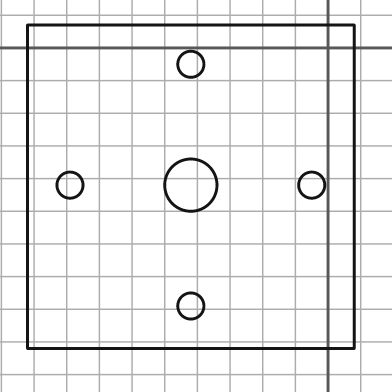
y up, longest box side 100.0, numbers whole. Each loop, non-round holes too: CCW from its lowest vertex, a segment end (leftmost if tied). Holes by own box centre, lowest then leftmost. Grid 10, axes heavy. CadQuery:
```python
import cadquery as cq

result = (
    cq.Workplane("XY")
    .moveTo(-92.0, -92.0)
    .lineTo(8.0, -92.0)
    .lineTo(8.0, 7.0)
    .lineTo(-92.0, 7.0)
    .close()
    .moveTo(-42.0, -79.0)
    .circle(4.0)
    .moveTo(-79.0, -42.0)
    .circle(4.0)
    .moveTo(-42.0, -42.0)
    .circle(8.0)
    .moveTo(-5.0, -42.0)
    .circle(4.0)
    .moveTo(-42.0, -5.0)
    .circle(4.0)
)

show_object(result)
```